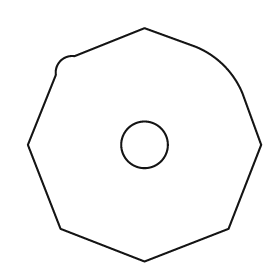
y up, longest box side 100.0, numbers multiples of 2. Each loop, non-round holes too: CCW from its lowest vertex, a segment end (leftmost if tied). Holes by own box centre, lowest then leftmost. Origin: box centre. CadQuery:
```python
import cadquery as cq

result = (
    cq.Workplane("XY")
    .moveTo(0.0, -50.0)
    .lineTo(36.0, -36.0)
    .lineTo(50.0, 0.0)
    .lineTo(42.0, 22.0)
    .threePointArc((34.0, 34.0), (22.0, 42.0))
    .lineTo(0.0, 50.0)
    .lineTo(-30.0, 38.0)
    .threePointArc((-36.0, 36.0), (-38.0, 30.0))
    .lineTo(-50.0, 0.0)
    .lineTo(-36.0, -36.0)
    .close()
    .moveTo(0.0, 0.0)
    .circle(10.0)
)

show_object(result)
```